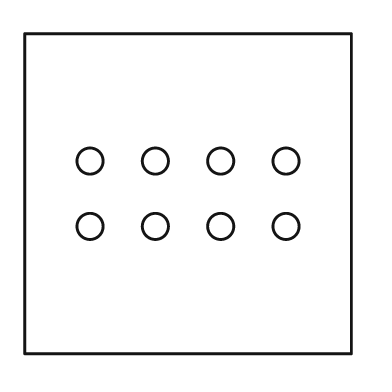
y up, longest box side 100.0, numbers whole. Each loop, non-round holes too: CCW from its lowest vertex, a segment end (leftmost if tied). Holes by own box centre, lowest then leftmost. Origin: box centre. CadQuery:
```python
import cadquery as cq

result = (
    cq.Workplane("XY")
    .moveTo(-50.0, -49.0)
    .lineTo(50.0, -49.0)
    .lineTo(50.0, 49.0)
    .lineTo(-50.0, 49.0)
    .close()
    .moveTo(-30.0, -10.0)
    .circle(4.0)
    .moveTo(-10.0, -10.0)
    .circle(4.0)
    .moveTo(10.0, -10.0)
    .circle(4.0)
    .moveTo(30.0, -10.0)
    .circle(4.0)
    .moveTo(-30.0, 10.0)
    .circle(4.0)
    .moveTo(-10.0, 10.0)
    .circle(4.0)
    .moveTo(10.0, 10.0)
    .circle(4.0)
    .moveTo(30.0, 10.0)
    .circle(4.0)
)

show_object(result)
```